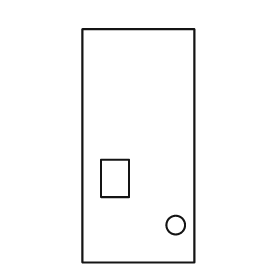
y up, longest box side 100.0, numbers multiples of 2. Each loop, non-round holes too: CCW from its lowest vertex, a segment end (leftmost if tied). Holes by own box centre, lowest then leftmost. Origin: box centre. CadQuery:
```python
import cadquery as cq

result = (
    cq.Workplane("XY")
    .moveTo(-24.0, -50.0)
    .lineTo(24.0, -50.0)
    .lineTo(24.0, 50.0)
    .lineTo(-24.0, 50.0)
    .close()
    .moveTo(16.0, -34.0)
    .circle(4.0)
    .moveTo(-16.0, -22.0)
    .lineTo(-4.0, -22.0)
    .lineTo(-4.0, -6.0)
    .lineTo(-16.0, -6.0)
    .close()
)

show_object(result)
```